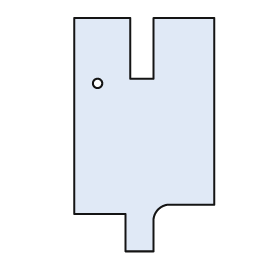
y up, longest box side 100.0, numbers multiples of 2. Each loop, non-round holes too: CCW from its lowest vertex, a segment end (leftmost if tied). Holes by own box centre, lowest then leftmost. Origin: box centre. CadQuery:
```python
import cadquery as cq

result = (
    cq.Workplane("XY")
    .moveTo(-8.0, -50.0)
    .lineTo(4.0, -50.0)
    .lineTo(4.0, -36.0)
    .threePointArc((6.0, -32.0), (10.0, -30.0))
    .lineTo(30.0, -30.0)
    .lineTo(30.0, 50.0)
    .lineTo(4.0, 50.0)
    .lineTo(4.0, 24.0)
    .lineTo(-6.0, 24.0)
    .lineTo(-6.0, 50.0)
    .lineTo(-30.0, 50.0)
    .lineTo(-30.0, -34.0)
    .lineTo(-8.0, -34.0)
    .close()
    .moveTo(-20.0, 22.0)
    .circle(2.0)
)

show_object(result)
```